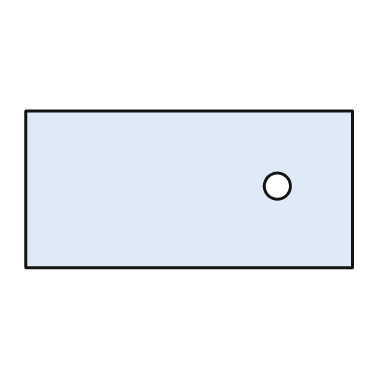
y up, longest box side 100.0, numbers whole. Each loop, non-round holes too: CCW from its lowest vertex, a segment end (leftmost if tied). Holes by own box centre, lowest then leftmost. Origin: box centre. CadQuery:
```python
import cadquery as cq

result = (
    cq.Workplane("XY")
    .moveTo(-50.0, -24.0)
    .lineTo(50.0, -24.0)
    .lineTo(50.0, 24.0)
    .lineTo(-50.0, 24.0)
    .close()
    .moveTo(27.0, 1.0)
    .circle(4.0)
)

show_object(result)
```